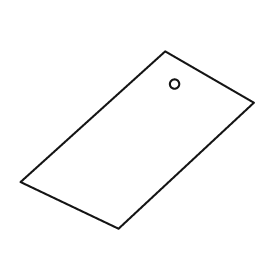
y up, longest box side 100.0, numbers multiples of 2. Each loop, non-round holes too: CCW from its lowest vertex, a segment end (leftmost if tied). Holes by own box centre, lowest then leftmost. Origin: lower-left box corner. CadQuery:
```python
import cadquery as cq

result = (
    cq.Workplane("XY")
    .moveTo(42.0, 0.0)
    .lineTo(100.0, 54.0)
    .lineTo(62.0, 76.0)
    .lineTo(0.0, 20.0)
    .close()
    .moveTo(66.0, 62.0)
    .circle(2.0)
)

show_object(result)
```